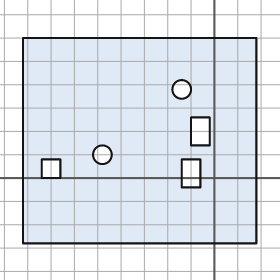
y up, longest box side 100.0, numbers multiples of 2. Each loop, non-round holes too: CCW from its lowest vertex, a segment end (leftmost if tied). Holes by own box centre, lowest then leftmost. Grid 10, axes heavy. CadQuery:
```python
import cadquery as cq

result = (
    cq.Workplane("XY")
    .moveTo(-82.0, -28.0)
    .lineTo(18.0, -28.0)
    .lineTo(18.0, 60.0)
    .lineTo(-82.0, 60.0)
    .close()
    .moveTo(-14.0, -4.0)
    .lineTo(-6.0, -4.0)
    .lineTo(-6.0, 8.0)
    .lineTo(-14.0, 8.0)
    .close()
    .moveTo(-74.0, 0.0)
    .lineTo(-66.0, 0.0)
    .lineTo(-66.0, 8.0)
    .lineTo(-74.0, 8.0)
    .close()
    .moveTo(-48.0, 10.0)
    .circle(4.0)
    .moveTo(-10.0, 14.0)
    .lineTo(-2.0, 14.0)
    .lineTo(-2.0, 26.0)
    .lineTo(-10.0, 26.0)
    .close()
    .moveTo(-14.0, 38.0)
    .circle(4.0)
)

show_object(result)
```